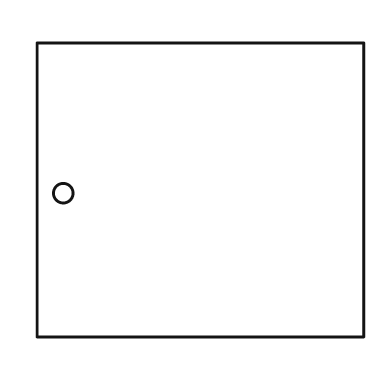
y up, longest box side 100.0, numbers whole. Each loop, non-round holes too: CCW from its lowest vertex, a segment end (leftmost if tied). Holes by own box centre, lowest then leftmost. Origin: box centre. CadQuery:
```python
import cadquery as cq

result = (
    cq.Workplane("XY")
    .moveTo(-50.0, -45.0)
    .lineTo(50.0, -45.0)
    .lineTo(50.0, 45.0)
    .lineTo(-50.0, 45.0)
    .close()
    .moveTo(-42.0, -1.0)
    .circle(3.0)
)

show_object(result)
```